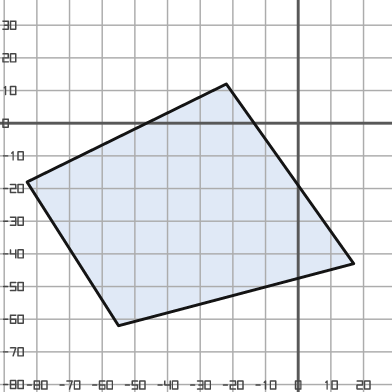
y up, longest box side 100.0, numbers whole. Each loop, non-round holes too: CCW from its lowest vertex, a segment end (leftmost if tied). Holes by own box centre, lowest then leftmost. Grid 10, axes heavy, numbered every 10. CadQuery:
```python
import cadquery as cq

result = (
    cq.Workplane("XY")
    .moveTo(-55.0, -62.0)
    .lineTo(17.0, -43.0)
    .lineTo(-22.0, 12.0)
    .lineTo(-83.0, -18.0)
    .close()
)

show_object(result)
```